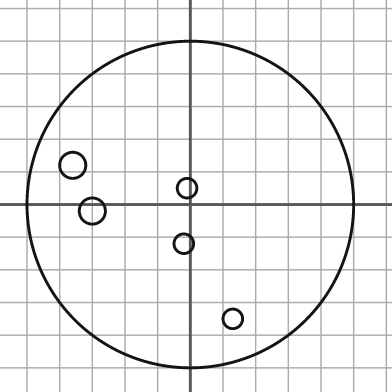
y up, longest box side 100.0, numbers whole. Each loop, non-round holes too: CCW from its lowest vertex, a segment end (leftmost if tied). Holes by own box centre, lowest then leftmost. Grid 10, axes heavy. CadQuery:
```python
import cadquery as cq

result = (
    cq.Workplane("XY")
    .moveTo(0.0, 0.0)
    .circle(50.0)
    .moveTo(13.0, -35.0)
    .circle(3.0)
    .moveTo(-2.0, -12.0)
    .circle(3.0)
    .moveTo(-30.0, -2.0)
    .circle(4.0)
    .moveTo(-1.0, 5.0)
    .circle(3.0)
    .moveTo(-36.0, 12.0)
    .circle(4.0)
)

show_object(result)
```